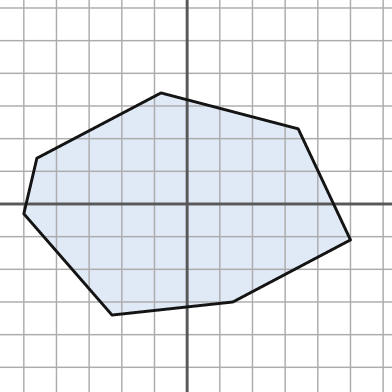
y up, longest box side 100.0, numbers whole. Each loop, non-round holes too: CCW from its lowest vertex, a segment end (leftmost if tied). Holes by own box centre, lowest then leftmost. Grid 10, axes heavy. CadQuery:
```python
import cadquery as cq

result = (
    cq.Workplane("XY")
    .moveTo(-23.0, -34.0)
    .lineTo(14.0, -30.0)
    .lineTo(50.0, -11.0)
    .lineTo(34.0, 23.0)
    .lineTo(-8.0, 34.0)
    .lineTo(-46.0, 14.0)
    .lineTo(-50.0, -3.0)
    .close()
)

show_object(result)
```